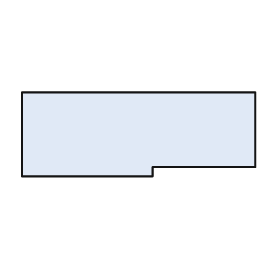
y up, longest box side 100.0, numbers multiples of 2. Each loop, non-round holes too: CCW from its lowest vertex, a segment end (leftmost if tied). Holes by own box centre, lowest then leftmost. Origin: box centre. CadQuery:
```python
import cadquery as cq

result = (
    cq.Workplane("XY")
    .moveTo(-50.0, -18.0)
    .lineTo(6.0, -18.0)
    .lineTo(6.0, -14.0)
    .lineTo(50.0, -14.0)
    .lineTo(50.0, 18.0)
    .lineTo(-50.0, 18.0)
    .close()
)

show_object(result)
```